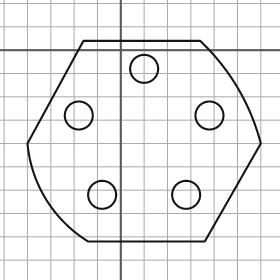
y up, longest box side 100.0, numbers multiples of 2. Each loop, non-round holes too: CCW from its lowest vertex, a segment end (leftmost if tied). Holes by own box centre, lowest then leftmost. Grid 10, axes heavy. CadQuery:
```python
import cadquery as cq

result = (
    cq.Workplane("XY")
    .moveTo(-14.0, -82.0)
    .lineTo(36.0, -82.0)
    .lineTo(60.0, -40.0)
    .threePointArc((50.0, -16.0), (34.0, 4.0))
    .lineTo(-16.0, 4.0)
    .lineTo(-40.0, -40.0)
    .threePointArc((-32.0, -64.0), (-14.0, -82.0))
    .close()
    .moveTo(-8.0, -62.0)
    .circle(6.0)
    .moveTo(28.0, -62.0)
    .circle(6.0)
    .moveTo(-18.0, -28.0)
    .circle(6.0)
    .moveTo(38.0, -28.0)
    .circle(6.0)
    .moveTo(10.0, -8.0)
    .circle(6.0)
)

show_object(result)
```